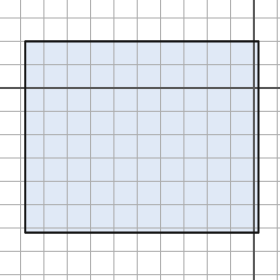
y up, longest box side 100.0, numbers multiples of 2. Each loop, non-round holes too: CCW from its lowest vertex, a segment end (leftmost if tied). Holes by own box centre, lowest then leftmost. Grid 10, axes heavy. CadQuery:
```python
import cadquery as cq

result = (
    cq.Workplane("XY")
    .moveTo(-98.0, -62.0)
    .lineTo(2.0, -62.0)
    .lineTo(2.0, 20.0)
    .lineTo(-98.0, 20.0)
    .close()
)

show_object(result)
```